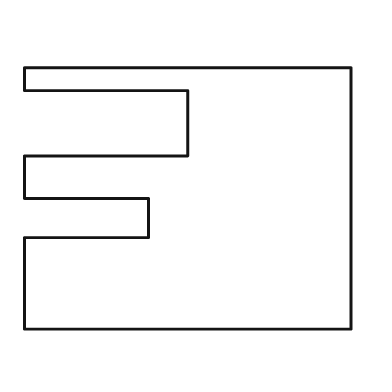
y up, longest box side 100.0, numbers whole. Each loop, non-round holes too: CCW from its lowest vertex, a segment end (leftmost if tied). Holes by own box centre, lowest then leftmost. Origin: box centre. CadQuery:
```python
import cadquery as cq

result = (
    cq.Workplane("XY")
    .moveTo(-50.0, -40.0)
    .lineTo(50.0, -40.0)
    .lineTo(50.0, 40.0)
    .lineTo(-50.0, 40.0)
    .lineTo(-50.0, 33.0)
    .lineTo(0.0, 33.0)
    .lineTo(0.0, 13.0)
    .lineTo(-50.0, 13.0)
    .lineTo(-50.0, 0.0)
    .lineTo(-12.0, 0.0)
    .lineTo(-12.0, -12.0)
    .lineTo(-50.0, -12.0)
    .close()
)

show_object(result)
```